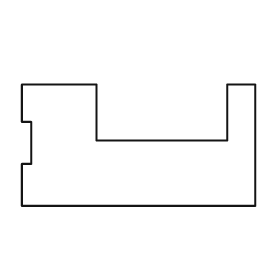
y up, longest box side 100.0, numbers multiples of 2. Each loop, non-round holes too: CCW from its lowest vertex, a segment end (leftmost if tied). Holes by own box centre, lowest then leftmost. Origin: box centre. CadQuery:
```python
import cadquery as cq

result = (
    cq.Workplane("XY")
    .moveTo(-50.0, -26.0)
    .lineTo(50.0, -26.0)
    .lineTo(50.0, 26.0)
    .lineTo(38.0, 26.0)
    .lineTo(38.0, 2.0)
    .lineTo(-18.0, 2.0)
    .lineTo(-18.0, 26.0)
    .lineTo(-50.0, 26.0)
    .lineTo(-50.0, 10.0)
    .lineTo(-46.0, 10.0)
    .lineTo(-46.0, -8.0)
    .lineTo(-50.0, -8.0)
    .close()
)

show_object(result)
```